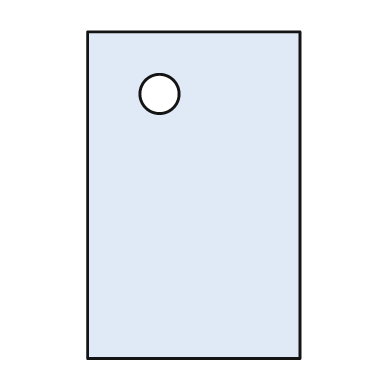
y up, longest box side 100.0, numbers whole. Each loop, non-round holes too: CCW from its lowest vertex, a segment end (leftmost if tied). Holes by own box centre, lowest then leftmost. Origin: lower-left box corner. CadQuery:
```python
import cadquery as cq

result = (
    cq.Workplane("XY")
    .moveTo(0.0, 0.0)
    .lineTo(65.0, 0.0)
    .lineTo(65.0, 100.0)
    .lineTo(0.0, 100.0)
    .close()
    .moveTo(22.0, 81.0)
    .circle(6.0)
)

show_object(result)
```